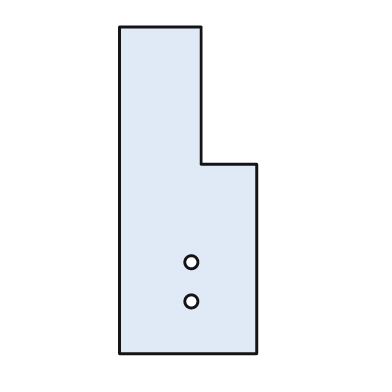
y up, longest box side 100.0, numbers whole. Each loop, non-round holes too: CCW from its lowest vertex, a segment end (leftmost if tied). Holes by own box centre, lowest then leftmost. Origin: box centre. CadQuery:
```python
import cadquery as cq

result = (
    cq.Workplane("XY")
    .moveTo(-21.0, -50.0)
    .lineTo(21.0, -50.0)
    .lineTo(21.0, 8.0)
    .lineTo(4.0, 8.0)
    .lineTo(4.0, 50.0)
    .lineTo(-21.0, 50.0)
    .close()
    .moveTo(1.0, -34.0)
    .circle(2.0)
    .moveTo(1.0, -22.0)
    .circle(2.0)
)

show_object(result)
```